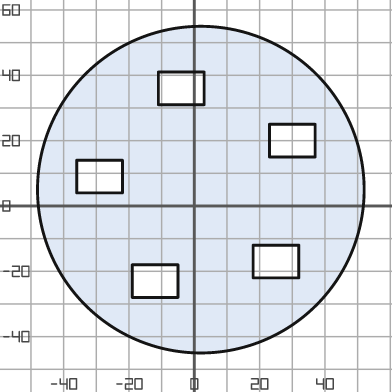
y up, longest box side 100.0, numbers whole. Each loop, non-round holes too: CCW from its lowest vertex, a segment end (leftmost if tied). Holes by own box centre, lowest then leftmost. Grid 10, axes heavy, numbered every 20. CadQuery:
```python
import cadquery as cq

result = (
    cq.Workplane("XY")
    .moveTo(2.0, 5.0)
    .circle(50.0)
    .moveTo(-19.0, -28.0)
    .lineTo(-5.0, -28.0)
    .lineTo(-5.0, -18.0)
    .lineTo(-19.0, -18.0)
    .close()
    .moveTo(18.0, -22.0)
    .lineTo(32.0, -22.0)
    .lineTo(32.0, -12.0)
    .lineTo(18.0, -12.0)
    .close()
    .moveTo(-36.0, 4.0)
    .lineTo(-22.0, 4.0)
    .lineTo(-22.0, 14.0)
    .lineTo(-36.0, 14.0)
    .close()
    .moveTo(23.0, 15.0)
    .lineTo(37.0, 15.0)
    .lineTo(37.0, 25.0)
    .lineTo(23.0, 25.0)
    .close()
    .moveTo(-11.0, 31.0)
    .lineTo(3.0, 31.0)
    .lineTo(3.0, 41.0)
    .lineTo(-11.0, 41.0)
    .close()
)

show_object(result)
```